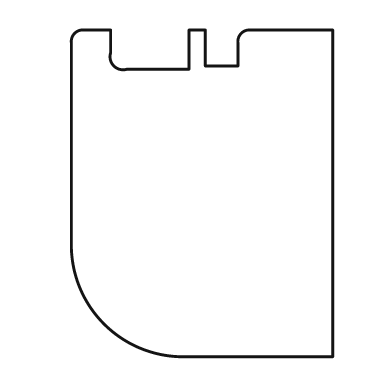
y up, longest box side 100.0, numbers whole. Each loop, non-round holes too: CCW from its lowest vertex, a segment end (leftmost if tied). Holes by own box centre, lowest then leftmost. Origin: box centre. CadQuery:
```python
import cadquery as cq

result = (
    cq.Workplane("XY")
    .moveTo(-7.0, -50.0)
    .lineTo(40.0, -50.0)
    .lineTo(40.0, 50.0)
    .lineTo(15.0, 50.0)
    .threePointArc((12.0, 49.0), (11.0, 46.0))
    .lineTo(11.0, 39.0)
    .lineTo(1.0, 39.0)
    .lineTo(1.0, 50.0)
    .lineTo(-4.0, 50.0)
    .lineTo(-4.0, 38.0)
    .lineTo(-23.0, 38.0)
    .threePointArc((-27.0, 39.0), (-28.0, 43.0))
    .lineTo(-28.0, 50.0)
    .lineTo(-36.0, 50.0)
    .threePointArc((-39.0, 49.0), (-40.0, 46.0))
    .lineTo(-40.0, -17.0)
    .threePointArc((-30.0, -40.0), (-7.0, -50.0))
    .close()
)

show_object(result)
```